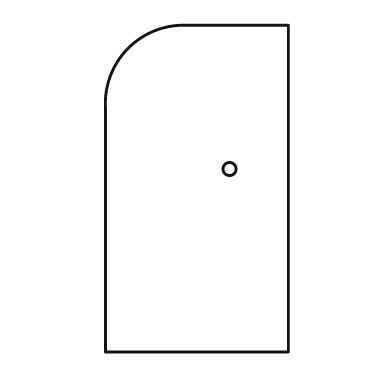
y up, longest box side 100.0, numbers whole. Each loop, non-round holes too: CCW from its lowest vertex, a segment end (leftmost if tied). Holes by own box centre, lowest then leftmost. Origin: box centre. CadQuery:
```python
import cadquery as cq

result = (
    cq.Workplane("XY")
    .moveTo(-28.0, -50.0)
    .lineTo(28.0, -50.0)
    .lineTo(28.0, 50.0)
    .lineTo(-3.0, 50.0)
    .threePointArc((-21.0, 43.0), (-28.0, 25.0))
    .close()
    .moveTo(10.0, 6.0)
    .circle(2.0)
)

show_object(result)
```